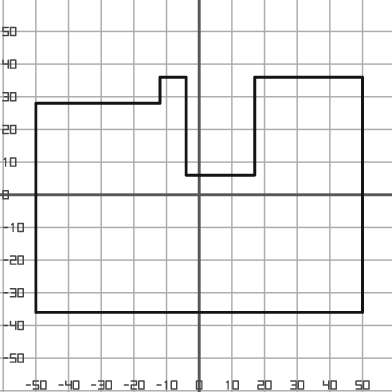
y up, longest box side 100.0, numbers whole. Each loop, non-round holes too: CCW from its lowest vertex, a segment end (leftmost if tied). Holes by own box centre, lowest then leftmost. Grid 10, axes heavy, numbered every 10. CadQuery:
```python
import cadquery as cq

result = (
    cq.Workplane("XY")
    .moveTo(-50.0, -36.0)
    .lineTo(50.0, -36.0)
    .lineTo(50.0, 36.0)
    .lineTo(17.0, 36.0)
    .lineTo(17.0, 6.0)
    .lineTo(-4.0, 6.0)
    .lineTo(-4.0, 36.0)
    .lineTo(-12.0, 36.0)
    .lineTo(-12.0, 28.0)
    .lineTo(-50.0, 28.0)
    .close()
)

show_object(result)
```